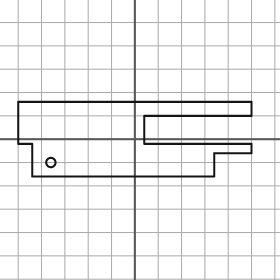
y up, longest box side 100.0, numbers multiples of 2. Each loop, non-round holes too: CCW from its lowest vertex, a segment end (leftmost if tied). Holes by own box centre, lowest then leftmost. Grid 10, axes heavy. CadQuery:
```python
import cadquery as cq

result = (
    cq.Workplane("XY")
    .moveTo(-44.0, -16.0)
    .lineTo(34.0, -16.0)
    .lineTo(34.0, -6.0)
    .lineTo(50.0, -6.0)
    .lineTo(50.0, -2.0)
    .lineTo(4.0, -2.0)
    .lineTo(4.0, 10.0)
    .lineTo(50.0, 10.0)
    .lineTo(50.0, 16.0)
    .lineTo(-50.0, 16.0)
    .lineTo(-50.0, -2.0)
    .lineTo(-44.0, -2.0)
    .close()
    .moveTo(-36.0, -10.0)
    .circle(2.0)
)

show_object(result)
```